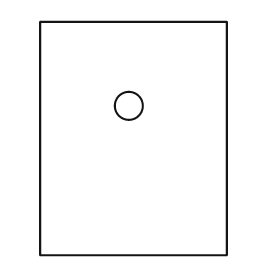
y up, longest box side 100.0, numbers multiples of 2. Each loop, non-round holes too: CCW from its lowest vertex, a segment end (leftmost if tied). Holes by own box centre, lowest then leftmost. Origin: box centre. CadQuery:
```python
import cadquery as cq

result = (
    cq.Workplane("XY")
    .moveTo(-40.0, -50.0)
    .lineTo(40.0, -50.0)
    .lineTo(40.0, 50.0)
    .lineTo(-40.0, 50.0)
    .close()
    .moveTo(-2.0, 14.0)
    .circle(6.0)
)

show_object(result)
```